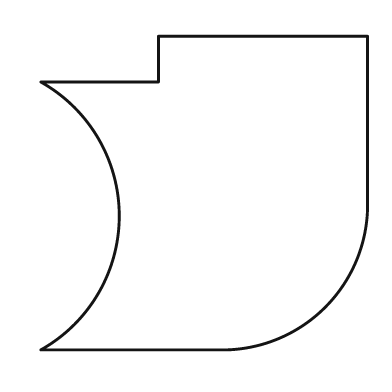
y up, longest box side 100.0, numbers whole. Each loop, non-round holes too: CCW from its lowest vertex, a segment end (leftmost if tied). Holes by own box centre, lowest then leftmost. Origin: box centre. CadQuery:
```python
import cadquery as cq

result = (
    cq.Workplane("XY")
    .moveTo(-50.0, -48.0)
    .lineTo(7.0, -48.0)
    .threePointArc((37.0, -35.0), (50.0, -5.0))
    .lineTo(50.0, 48.0)
    .lineTo(-14.0, 48.0)
    .lineTo(-14.0, 34.0)
    .lineTo(-50.0, 34.0)
    .threePointArc((-26.0, -7.0), (-50.0, -48.0))
    .close()
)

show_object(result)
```